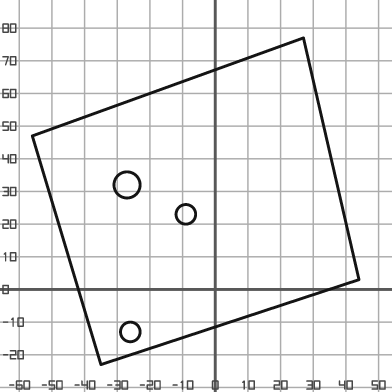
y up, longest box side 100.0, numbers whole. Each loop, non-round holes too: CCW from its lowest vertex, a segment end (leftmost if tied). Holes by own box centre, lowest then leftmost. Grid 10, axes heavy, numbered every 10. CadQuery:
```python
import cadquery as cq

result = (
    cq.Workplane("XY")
    .moveTo(-35.0, -23.0)
    .lineTo(44.0, 3.0)
    .lineTo(27.0, 77.0)
    .lineTo(-56.0, 47.0)
    .close()
    .moveTo(-26.0, -13.0)
    .circle(3.0)
    .moveTo(-9.0, 23.0)
    .circle(3.0)
    .moveTo(-27.0, 32.0)
    .circle(4.0)
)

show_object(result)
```